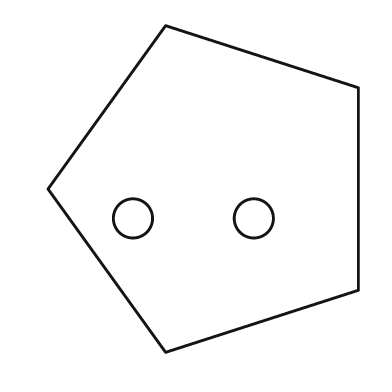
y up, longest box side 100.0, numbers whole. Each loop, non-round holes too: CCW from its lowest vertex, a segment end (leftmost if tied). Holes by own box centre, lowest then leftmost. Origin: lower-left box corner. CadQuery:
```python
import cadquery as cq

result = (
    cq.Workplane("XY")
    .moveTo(36.0, 0.0)
    .lineTo(95.0, 19.0)
    .lineTo(95.0, 81.0)
    .lineTo(36.0, 100.0)
    .lineTo(0.0, 50.0)
    .close()
    .moveTo(26.0, 41.0)
    .circle(6.0)
    .moveTo(63.0, 41.0)
    .circle(6.0)
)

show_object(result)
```